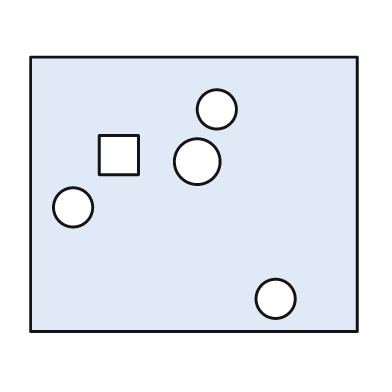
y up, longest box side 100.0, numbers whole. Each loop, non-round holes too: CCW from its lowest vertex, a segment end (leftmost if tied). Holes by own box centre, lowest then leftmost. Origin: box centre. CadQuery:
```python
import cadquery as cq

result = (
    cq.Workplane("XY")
    .moveTo(-50.0, -42.0)
    .lineTo(50.0, -42.0)
    .lineTo(50.0, 42.0)
    .lineTo(-50.0, 42.0)
    .close()
    .moveTo(25.0, -32.0)
    .circle(6.0)
    .moveTo(-37.0, -4.0)
    .circle(6.0)
    .moveTo(1.0, 10.0)
    .circle(7.0)
    .moveTo(-29.0, 6.0)
    .lineTo(-17.0, 6.0)
    .lineTo(-17.0, 18.0)
    .lineTo(-29.0, 18.0)
    .close()
    .moveTo(7.0, 26.0)
    .circle(6.0)
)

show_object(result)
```